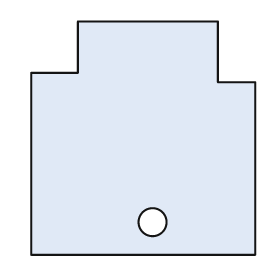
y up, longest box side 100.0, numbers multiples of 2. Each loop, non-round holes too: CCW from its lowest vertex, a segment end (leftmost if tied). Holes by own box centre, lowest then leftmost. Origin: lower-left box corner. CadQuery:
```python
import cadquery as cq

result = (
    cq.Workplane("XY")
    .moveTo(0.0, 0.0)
    .lineTo(96.0, 0.0)
    .lineTo(96.0, 74.0)
    .lineTo(80.0, 74.0)
    .lineTo(80.0, 100.0)
    .lineTo(20.0, 100.0)
    .lineTo(20.0, 78.0)
    .lineTo(0.0, 78.0)
    .close()
    .moveTo(52.0, 14.0)
    .circle(6.0)
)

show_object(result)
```